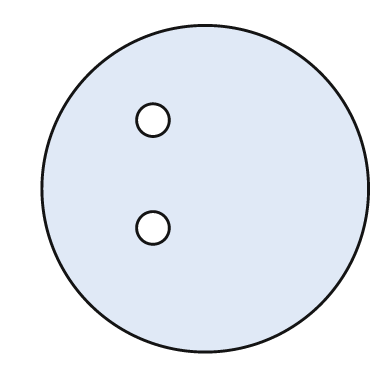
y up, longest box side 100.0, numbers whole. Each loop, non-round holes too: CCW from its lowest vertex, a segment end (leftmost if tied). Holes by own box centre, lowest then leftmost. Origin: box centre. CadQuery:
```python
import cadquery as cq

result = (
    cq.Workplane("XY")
    .moveTo(0.0, 0.0)
    .circle(50.0)
    .moveTo(-16.0, -12.0)
    .circle(5.0)
    .moveTo(-16.0, 21.0)
    .circle(5.0)
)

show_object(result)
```